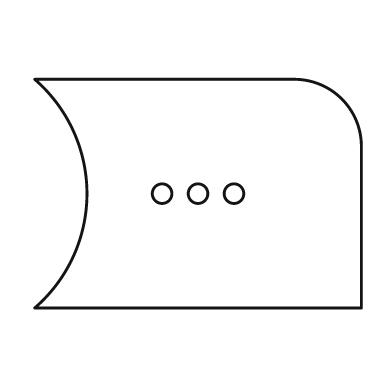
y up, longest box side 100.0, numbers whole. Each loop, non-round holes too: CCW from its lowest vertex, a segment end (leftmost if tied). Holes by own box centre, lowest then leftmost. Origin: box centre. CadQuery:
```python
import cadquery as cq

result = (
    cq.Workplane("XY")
    .moveTo(-50.0, -35.0)
    .lineTo(50.0, -35.0)
    .lineTo(50.0, 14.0)
    .threePointArc((44.0, 29.0), (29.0, 35.0))
    .lineTo(-50.0, 35.0)
    .threePointArc((-34.0, 0.0), (-50.0, -35.0))
    .close()
    .moveTo(-11.0, 0.0)
    .circle(3.0)
    .moveTo(0.0, 0.0)
    .circle(3.0)
    .moveTo(11.0, 0.0)
    .circle(3.0)
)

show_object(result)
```